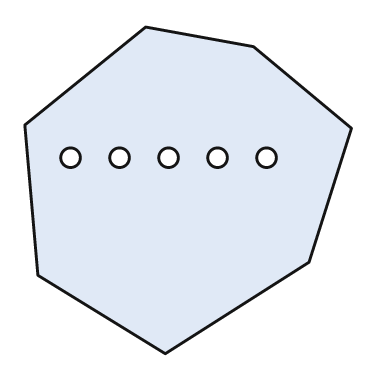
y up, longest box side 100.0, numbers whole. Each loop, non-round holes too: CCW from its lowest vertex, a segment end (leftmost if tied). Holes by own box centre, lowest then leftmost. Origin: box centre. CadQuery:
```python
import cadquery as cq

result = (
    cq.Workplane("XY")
    .moveTo(-7.0, -50.0)
    .lineTo(37.0, -22.0)
    .lineTo(50.0, 19.0)
    .lineTo(20.0, 44.0)
    .lineTo(-13.0, 50.0)
    .lineTo(-50.0, 20.0)
    .lineTo(-46.0, -26.0)
    .close()
    .moveTo(-36.0, 10.0)
    .circle(3.0)
    .moveTo(-21.0, 10.0)
    .circle(3.0)
    .moveTo(-6.0, 10.0)
    .circle(3.0)
    .moveTo(9.0, 10.0)
    .circle(3.0)
    .moveTo(24.0, 10.0)
    .circle(3.0)
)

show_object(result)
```